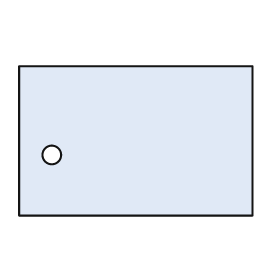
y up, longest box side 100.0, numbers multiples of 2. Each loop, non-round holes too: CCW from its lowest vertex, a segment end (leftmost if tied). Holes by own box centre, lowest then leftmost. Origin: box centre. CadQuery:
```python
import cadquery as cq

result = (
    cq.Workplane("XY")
    .moveTo(-50.0, -32.0)
    .lineTo(50.0, -32.0)
    .lineTo(50.0, 32.0)
    .lineTo(-50.0, 32.0)
    .close()
    .moveTo(-36.0, -6.0)
    .circle(4.0)
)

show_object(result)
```